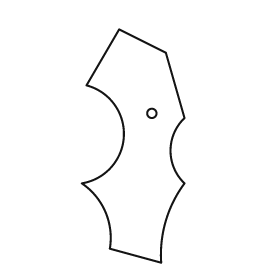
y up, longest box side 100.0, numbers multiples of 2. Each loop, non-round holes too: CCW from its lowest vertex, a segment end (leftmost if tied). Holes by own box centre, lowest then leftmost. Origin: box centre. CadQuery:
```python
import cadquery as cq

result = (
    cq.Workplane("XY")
    .moveTo(12.0, -50.0)
    .threePointArc((14.0, -32.0), (22.0, -16.0))
    .threePointArc((16.0, -2.0), (22.0, 12.0))
    .lineTo(14.0, 40.0)
    .lineTo(-6.0, 50.0)
    .lineTo(-20.0, 26.0)
    .threePointArc((-4.0, 4.0), (-22.0, -16.0))
    .threePointArc((-12.0, -28.0), (-10.0, -44.0))
    .close()
    .moveTo(8.0, 14.0)
    .circle(2.0)
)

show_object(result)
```